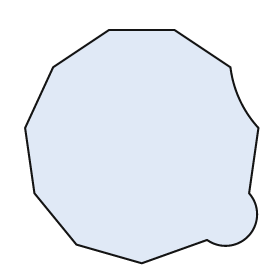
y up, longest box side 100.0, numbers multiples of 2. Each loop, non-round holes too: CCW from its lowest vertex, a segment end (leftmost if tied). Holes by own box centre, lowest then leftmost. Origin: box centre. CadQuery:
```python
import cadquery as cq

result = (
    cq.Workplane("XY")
    .moveTo(0.0, -50.0)
    .lineTo(28.0, -40.0)
    .threePointArc((46.0, -38.0), (46.0, -20.0))
    .lineTo(50.0, 8.0)
    .threePointArc((42.0, 20.0), (38.0, 34.0))
    .lineTo(14.0, 50.0)
    .lineTo(-14.0, 50.0)
    .lineTo(-38.0, 34.0)
    .lineTo(-50.0, 8.0)
    .lineTo(-46.0, -20.0)
    .lineTo(-28.0, -42.0)
    .close()
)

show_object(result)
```